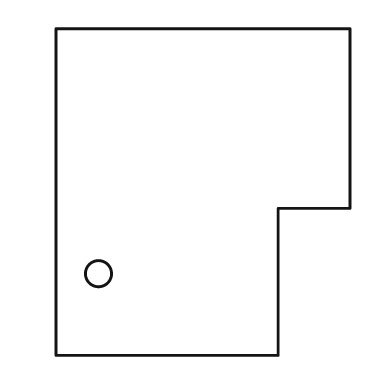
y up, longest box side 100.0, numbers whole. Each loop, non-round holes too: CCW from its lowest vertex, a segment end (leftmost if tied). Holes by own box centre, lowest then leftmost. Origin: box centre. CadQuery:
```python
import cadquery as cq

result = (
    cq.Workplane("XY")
    .moveTo(-45.0, -50.0)
    .lineTo(23.0, -50.0)
    .lineTo(23.0, -5.0)
    .lineTo(45.0, -5.0)
    .lineTo(45.0, 50.0)
    .lineTo(-45.0, 50.0)
    .close()
    .moveTo(-32.0, -25.0)
    .circle(4.0)
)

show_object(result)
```